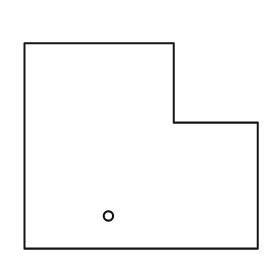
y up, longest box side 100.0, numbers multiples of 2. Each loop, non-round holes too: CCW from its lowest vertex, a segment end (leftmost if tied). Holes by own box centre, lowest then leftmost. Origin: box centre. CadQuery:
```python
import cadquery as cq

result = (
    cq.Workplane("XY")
    .moveTo(-50.0, -44.0)
    .lineTo(50.0, -44.0)
    .lineTo(50.0, 10.0)
    .lineTo(14.0, 10.0)
    .lineTo(14.0, 44.0)
    .lineTo(-50.0, 44.0)
    .close()
    .moveTo(-14.0, -30.0)
    .circle(2.0)
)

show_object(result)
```